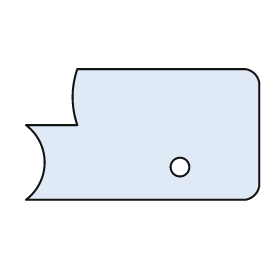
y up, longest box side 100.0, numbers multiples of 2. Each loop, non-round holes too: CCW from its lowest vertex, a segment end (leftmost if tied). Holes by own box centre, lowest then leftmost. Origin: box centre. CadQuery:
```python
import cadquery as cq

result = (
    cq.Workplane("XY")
    .moveTo(-50.0, -28.0)
    .lineTo(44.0, -28.0)
    .threePointArc((48.0, -26.0), (50.0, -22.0))
    .lineTo(50.0, 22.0)
    .threePointArc((48.0, 26.0), (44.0, 28.0))
    .lineTo(-28.0, 28.0)
    .threePointArc((-30.0, 16.0), (-28.0, 4.0))
    .lineTo(-50.0, 4.0)
    .threePointArc((-42.0, -12.0), (-50.0, -28.0))
    .close()
    .moveTo(16.0, -14.0)
    .circle(4.0)
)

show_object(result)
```